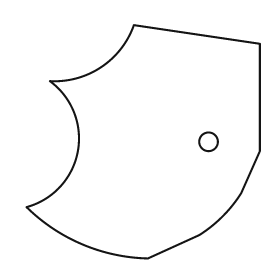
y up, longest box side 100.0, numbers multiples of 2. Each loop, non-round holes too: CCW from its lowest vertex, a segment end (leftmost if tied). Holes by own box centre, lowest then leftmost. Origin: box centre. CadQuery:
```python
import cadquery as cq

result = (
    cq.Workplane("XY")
    .moveTo(2.0, -50.0)
    .lineTo(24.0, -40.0)
    .threePointArc((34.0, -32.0), (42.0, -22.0))
    .lineTo(50.0, -4.0)
    .lineTo(50.0, 42.0)
    .lineTo(-4.0, 50.0)
    .threePointArc((-18.0, 32.0), (-40.0, 26.0))
    .threePointArc((-28.0, -4.0), (-50.0, -28.0))
    .threePointArc((-26.0, -44.0), (2.0, -50.0))
    .close()
    .moveTo(28.0, 0.0)
    .circle(4.0)
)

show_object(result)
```